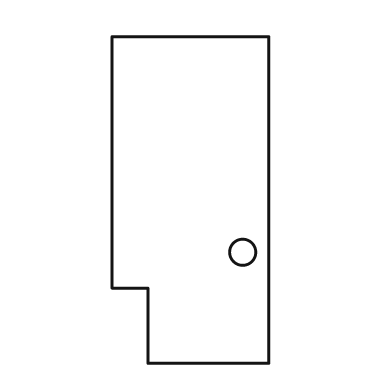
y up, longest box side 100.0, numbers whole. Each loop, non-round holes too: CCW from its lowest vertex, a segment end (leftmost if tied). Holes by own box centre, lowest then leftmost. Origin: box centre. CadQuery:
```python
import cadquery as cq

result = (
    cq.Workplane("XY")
    .moveTo(-13.0, -50.0)
    .lineTo(24.0, -50.0)
    .lineTo(24.0, 50.0)
    .lineTo(-24.0, 50.0)
    .lineTo(-24.0, -27.0)
    .lineTo(-13.0, -27.0)
    .close()
    .moveTo(16.0, -16.0)
    .circle(4.0)
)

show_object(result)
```